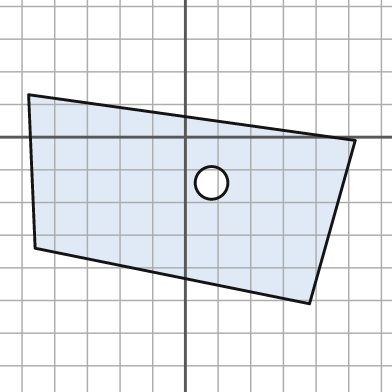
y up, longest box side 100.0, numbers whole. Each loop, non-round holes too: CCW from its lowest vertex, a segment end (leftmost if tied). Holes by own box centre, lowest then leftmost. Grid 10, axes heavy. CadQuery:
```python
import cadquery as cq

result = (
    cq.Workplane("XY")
    .moveTo(38.0, -51.0)
    .lineTo(52.0, -1.0)
    .lineTo(-48.0, 13.0)
    .lineTo(-46.0, -34.0)
    .close()
    .moveTo(8.0, -14.0)
    .circle(5.0)
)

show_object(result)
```